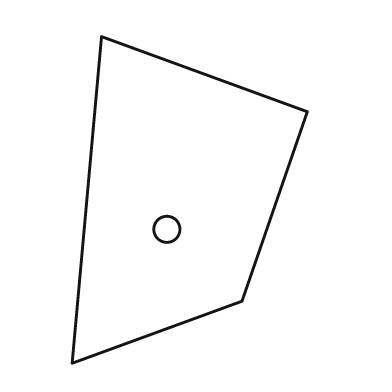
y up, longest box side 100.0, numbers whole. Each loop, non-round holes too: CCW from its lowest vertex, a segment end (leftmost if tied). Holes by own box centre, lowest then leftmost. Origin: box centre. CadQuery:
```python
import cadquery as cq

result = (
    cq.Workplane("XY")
    .moveTo(-36.0, -50.0)
    .lineTo(16.0, -31.0)
    .lineTo(36.0, 27.0)
    .lineTo(-27.0, 50.0)
    .close()
    .moveTo(-7.0, -9.0)
    .circle(4.0)
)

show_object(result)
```